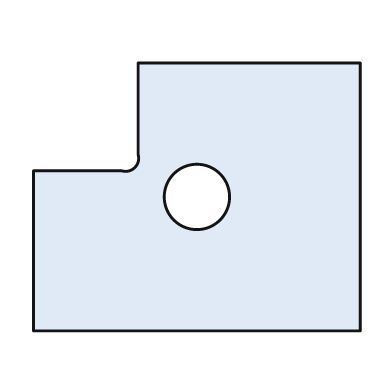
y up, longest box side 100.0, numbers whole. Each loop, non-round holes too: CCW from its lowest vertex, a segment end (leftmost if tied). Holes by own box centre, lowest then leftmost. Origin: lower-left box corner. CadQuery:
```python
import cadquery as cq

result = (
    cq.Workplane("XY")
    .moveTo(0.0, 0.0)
    .lineTo(100.0, 0.0)
    .lineTo(100.0, 82.0)
    .lineTo(32.0, 82.0)
    .lineTo(32.0, 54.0)
    .threePointArc((31.0, 50.0), (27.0, 49.0))
    .lineTo(0.0, 49.0)
    .close()
    .moveTo(50.0, 41.0)
    .circle(10.0)
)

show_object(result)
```